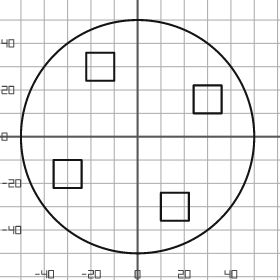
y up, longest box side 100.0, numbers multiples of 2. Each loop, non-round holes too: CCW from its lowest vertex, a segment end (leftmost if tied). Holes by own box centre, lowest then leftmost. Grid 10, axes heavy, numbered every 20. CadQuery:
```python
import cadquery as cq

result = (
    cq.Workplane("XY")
    .moveTo(0.0, 0.0)
    .circle(50.0)
    .moveTo(10.0, -36.0)
    .lineTo(22.0, -36.0)
    .lineTo(22.0, -24.0)
    .lineTo(10.0, -24.0)
    .close()
    .moveTo(-36.0, -22.0)
    .lineTo(-24.0, -22.0)
    .lineTo(-24.0, -10.0)
    .lineTo(-36.0, -10.0)
    .close()
    .moveTo(24.0, 10.0)
    .lineTo(36.0, 10.0)
    .lineTo(36.0, 22.0)
    .lineTo(24.0, 22.0)
    .close()
    .moveTo(-22.0, 24.0)
    .lineTo(-10.0, 24.0)
    .lineTo(-10.0, 36.0)
    .lineTo(-22.0, 36.0)
    .close()
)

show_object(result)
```